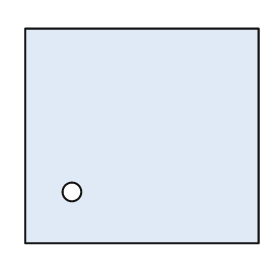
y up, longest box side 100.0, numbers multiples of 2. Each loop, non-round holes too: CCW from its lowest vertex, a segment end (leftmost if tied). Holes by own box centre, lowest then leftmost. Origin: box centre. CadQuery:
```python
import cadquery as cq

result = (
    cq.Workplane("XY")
    .moveTo(-50.0, -46.0)
    .lineTo(50.0, -46.0)
    .lineTo(50.0, 46.0)
    .lineTo(-50.0, 46.0)
    .close()
    .moveTo(-30.0, -24.0)
    .circle(4.0)
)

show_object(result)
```